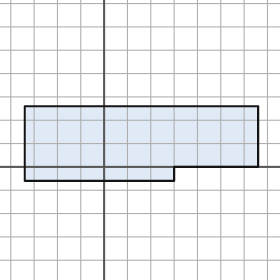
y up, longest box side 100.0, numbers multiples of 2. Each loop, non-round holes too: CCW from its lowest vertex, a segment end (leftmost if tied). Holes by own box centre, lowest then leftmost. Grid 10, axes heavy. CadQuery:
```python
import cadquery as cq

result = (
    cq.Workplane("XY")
    .moveTo(-34.0, -6.0)
    .lineTo(30.0, -6.0)
    .lineTo(30.0, 0.0)
    .lineTo(66.0, 0.0)
    .lineTo(66.0, 26.0)
    .lineTo(-34.0, 26.0)
    .close()
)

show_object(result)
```